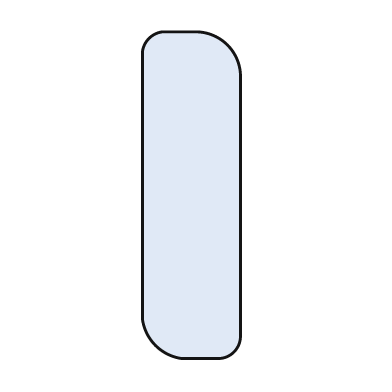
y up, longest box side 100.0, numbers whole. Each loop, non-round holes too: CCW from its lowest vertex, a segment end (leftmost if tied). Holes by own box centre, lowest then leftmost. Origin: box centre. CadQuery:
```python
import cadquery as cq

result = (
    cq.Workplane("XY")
    .moveTo(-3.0, -50.0)
    .lineTo(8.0, -50.0)
    .threePointArc((13.0, -48.0), (15.0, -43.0))
    .lineTo(15.0, 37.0)
    .threePointArc((11.0, 46.0), (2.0, 50.0))
    .lineTo(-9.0, 50.0)
    .threePointArc((-13.0, 48.0), (-15.0, 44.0))
    .lineTo(-15.0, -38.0)
    .threePointArc((-11.0, -46.0), (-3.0, -50.0))
    .close()
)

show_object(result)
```